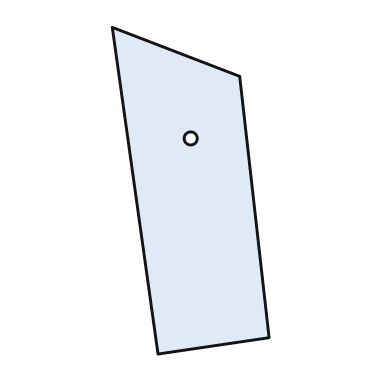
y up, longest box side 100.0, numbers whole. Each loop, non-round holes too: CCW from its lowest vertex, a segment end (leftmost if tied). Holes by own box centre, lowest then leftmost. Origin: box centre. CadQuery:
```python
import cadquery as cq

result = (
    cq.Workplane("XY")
    .moveTo(-10.0, -50.0)
    .lineTo(24.0, -45.0)
    .lineTo(15.0, 35.0)
    .lineTo(-24.0, 50.0)
    .close()
    .moveTo(0.0, 16.0)
    .circle(2.0)
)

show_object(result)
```